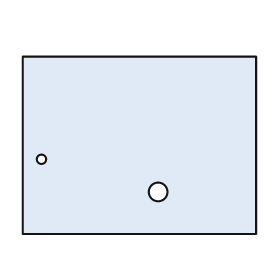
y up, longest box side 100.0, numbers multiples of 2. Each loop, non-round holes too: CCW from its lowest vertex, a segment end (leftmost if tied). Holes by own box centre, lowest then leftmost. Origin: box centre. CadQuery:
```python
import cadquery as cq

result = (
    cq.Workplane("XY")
    .moveTo(-50.0, -38.0)
    .lineTo(50.0, -38.0)
    .lineTo(50.0, 38.0)
    .lineTo(-50.0, 38.0)
    .close()
    .moveTo(8.0, -20.0)
    .circle(4.0)
    .moveTo(-42.0, -6.0)
    .circle(2.0)
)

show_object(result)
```